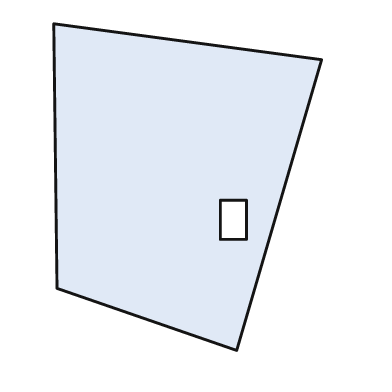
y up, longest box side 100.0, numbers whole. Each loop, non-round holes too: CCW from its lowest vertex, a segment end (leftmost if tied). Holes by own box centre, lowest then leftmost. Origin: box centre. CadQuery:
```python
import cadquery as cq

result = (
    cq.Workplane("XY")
    .moveTo(15.0, -50.0)
    .lineTo(41.0, 39.0)
    .lineTo(-41.0, 50.0)
    .lineTo(-40.0, -31.0)
    .close()
    .moveTo(10.0, -16.0)
    .lineTo(18.0, -16.0)
    .lineTo(18.0, -4.0)
    .lineTo(10.0, -4.0)
    .close()
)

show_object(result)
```